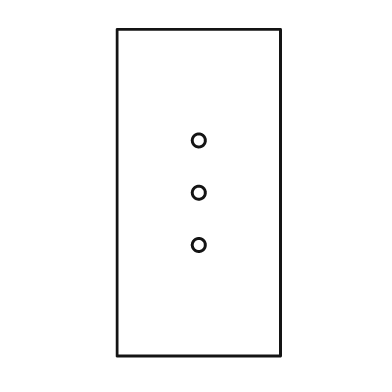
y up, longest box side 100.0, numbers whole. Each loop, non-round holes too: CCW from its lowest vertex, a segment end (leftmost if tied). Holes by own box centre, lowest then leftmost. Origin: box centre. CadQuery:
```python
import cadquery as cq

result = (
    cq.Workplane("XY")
    .moveTo(-25.0, -50.0)
    .lineTo(25.0, -50.0)
    .lineTo(25.0, 50.0)
    .lineTo(-25.0, 50.0)
    .close()
    .moveTo(0.0, -16.0)
    .circle(2.0)
    .moveTo(0.0, 0.0)
    .circle(2.0)
    .moveTo(0.0, 16.0)
    .circle(2.0)
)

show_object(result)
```